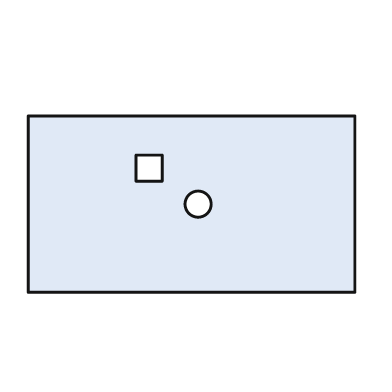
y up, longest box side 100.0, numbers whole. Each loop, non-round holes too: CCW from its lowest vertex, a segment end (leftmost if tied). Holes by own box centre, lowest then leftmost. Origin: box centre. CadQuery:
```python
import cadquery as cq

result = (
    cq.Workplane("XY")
    .moveTo(-50.0, -27.0)
    .lineTo(50.0, -27.0)
    .lineTo(50.0, 27.0)
    .lineTo(-50.0, 27.0)
    .close()
    .moveTo(2.0, 0.0)
    .circle(4.0)
    .moveTo(-17.0, 7.0)
    .lineTo(-9.0, 7.0)
    .lineTo(-9.0, 15.0)
    .lineTo(-17.0, 15.0)
    .close()
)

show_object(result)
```